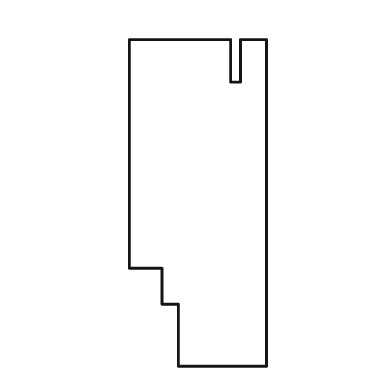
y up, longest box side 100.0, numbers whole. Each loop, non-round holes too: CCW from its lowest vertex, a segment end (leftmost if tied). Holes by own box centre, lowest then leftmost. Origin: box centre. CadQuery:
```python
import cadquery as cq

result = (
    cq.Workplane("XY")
    .moveTo(-6.0, -50.0)
    .lineTo(21.0, -50.0)
    .lineTo(21.0, 50.0)
    .lineTo(13.0, 50.0)
    .lineTo(13.0, 37.0)
    .lineTo(10.0, 37.0)
    .lineTo(10.0, 50.0)
    .lineTo(-21.0, 50.0)
    .lineTo(-21.0, -20.0)
    .lineTo(-11.0, -20.0)
    .lineTo(-11.0, -31.0)
    .lineTo(-6.0, -31.0)
    .close()
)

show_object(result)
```